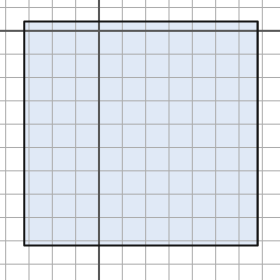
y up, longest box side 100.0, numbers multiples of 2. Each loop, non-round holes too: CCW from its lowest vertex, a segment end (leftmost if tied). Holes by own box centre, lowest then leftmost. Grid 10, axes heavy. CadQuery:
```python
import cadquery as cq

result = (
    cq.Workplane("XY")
    .moveTo(-32.0, -92.0)
    .lineTo(68.0, -92.0)
    .lineTo(68.0, 4.0)
    .lineTo(-32.0, 4.0)
    .close()
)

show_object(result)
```